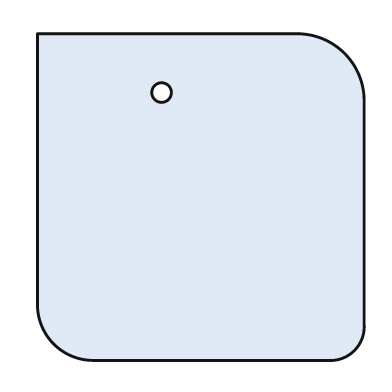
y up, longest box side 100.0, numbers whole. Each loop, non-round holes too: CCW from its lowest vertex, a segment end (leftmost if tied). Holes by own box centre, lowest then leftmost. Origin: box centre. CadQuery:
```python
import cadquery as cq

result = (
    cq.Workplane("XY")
    .moveTo(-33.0, -50.0)
    .lineTo(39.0, -50.0)
    .threePointArc((47.0, -47.0), (50.0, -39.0))
    .lineTo(50.0, 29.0)
    .threePointArc((44.0, 44.0), (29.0, 50.0))
    .lineTo(-50.0, 50.0)
    .lineTo(-50.0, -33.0)
    .threePointArc((-45.0, -45.0), (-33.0, -50.0))
    .close()
    .moveTo(-12.0, 32.0)
    .circle(3.0)
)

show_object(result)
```